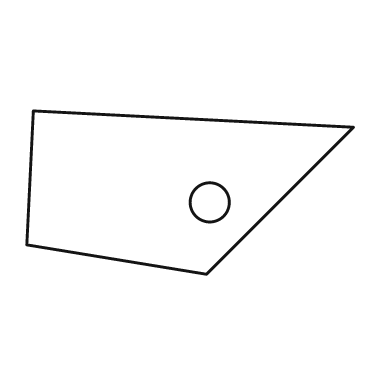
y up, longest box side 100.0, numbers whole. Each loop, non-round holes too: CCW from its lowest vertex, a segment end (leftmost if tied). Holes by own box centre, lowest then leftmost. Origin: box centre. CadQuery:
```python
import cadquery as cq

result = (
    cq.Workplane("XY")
    .moveTo(5.0, -25.0)
    .lineTo(50.0, 20.0)
    .lineTo(-48.0, 25.0)
    .lineTo(-50.0, -16.0)
    .close()
    .moveTo(6.0, -3.0)
    .circle(6.0)
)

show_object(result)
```